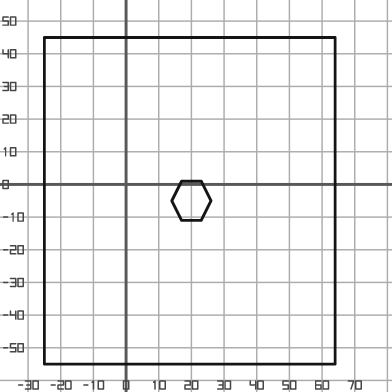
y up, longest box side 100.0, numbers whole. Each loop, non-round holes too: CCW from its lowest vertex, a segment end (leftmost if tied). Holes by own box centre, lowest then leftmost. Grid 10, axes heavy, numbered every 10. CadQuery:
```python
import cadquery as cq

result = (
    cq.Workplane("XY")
    .moveTo(-25.0, -55.0)
    .lineTo(64.0, -55.0)
    .lineTo(64.0, 45.0)
    .lineTo(-25.0, 45.0)
    .close()
    .moveTo(17.0, -11.0)
    .lineTo(23.0, -11.0)
    .lineTo(26.0, -5.0)
    .lineTo(23.0, 1.0)
    .lineTo(17.0, 1.0)
    .lineTo(14.0, -5.0)
    .close()
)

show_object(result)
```